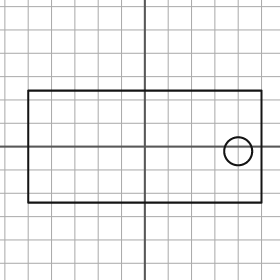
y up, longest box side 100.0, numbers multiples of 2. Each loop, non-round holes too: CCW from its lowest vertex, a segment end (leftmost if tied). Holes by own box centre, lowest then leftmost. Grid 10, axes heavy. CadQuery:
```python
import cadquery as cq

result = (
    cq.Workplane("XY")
    .moveTo(-50.0, -24.0)
    .lineTo(50.0, -24.0)
    .lineTo(50.0, 24.0)
    .lineTo(-50.0, 24.0)
    .close()
    .moveTo(40.0, -2.0)
    .circle(6.0)
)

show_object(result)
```